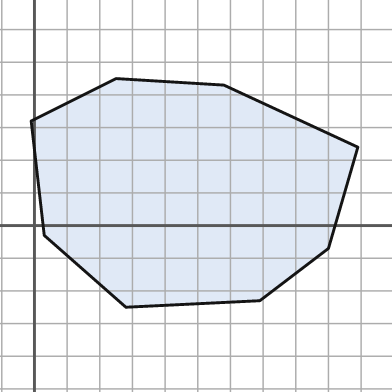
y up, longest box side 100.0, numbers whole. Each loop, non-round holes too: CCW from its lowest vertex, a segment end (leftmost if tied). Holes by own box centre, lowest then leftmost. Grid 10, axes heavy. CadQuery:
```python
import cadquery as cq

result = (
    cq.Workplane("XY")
    .moveTo(28.0, -25.0)
    .lineTo(69.0, -23.0)
    .lineTo(90.0, -7.0)
    .lineTo(99.0, 24.0)
    .lineTo(58.0, 43.0)
    .lineTo(25.0, 45.0)
    .lineTo(-1.0, 32.0)
    .lineTo(3.0, -3.0)
    .close()
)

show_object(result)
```